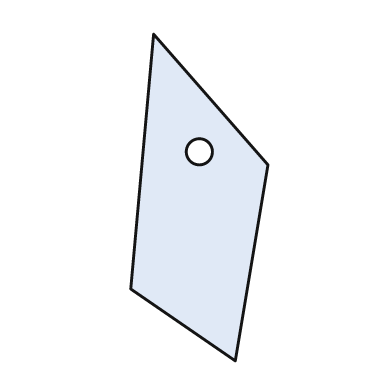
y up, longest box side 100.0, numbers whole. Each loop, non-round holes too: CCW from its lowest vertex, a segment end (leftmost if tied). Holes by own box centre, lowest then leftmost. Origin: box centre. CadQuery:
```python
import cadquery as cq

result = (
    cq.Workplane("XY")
    .moveTo(11.0, -50.0)
    .lineTo(21.0, 10.0)
    .lineTo(-14.0, 50.0)
    .lineTo(-21.0, -28.0)
    .close()
    .moveTo(0.0, 14.0)
    .circle(4.0)
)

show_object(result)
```